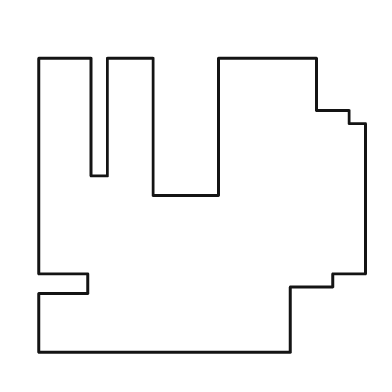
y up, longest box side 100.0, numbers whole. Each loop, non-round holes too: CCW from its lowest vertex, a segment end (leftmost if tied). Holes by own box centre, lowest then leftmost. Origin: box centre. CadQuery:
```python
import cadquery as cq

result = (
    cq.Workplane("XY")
    .moveTo(-50.0, -45.0)
    .lineTo(27.0, -45.0)
    .lineTo(27.0, -25.0)
    .lineTo(40.0, -25.0)
    .lineTo(40.0, -21.0)
    .lineTo(50.0, -21.0)
    .lineTo(50.0, 25.0)
    .lineTo(45.0, 25.0)
    .lineTo(45.0, 29.0)
    .lineTo(35.0, 29.0)
    .lineTo(35.0, 45.0)
    .lineTo(5.0, 45.0)
    .lineTo(5.0, 3.0)
    .lineTo(-15.0, 3.0)
    .lineTo(-15.0, 45.0)
    .lineTo(-29.0, 45.0)
    .lineTo(-29.0, 9.0)
    .lineTo(-34.0, 9.0)
    .lineTo(-34.0, 45.0)
    .lineTo(-50.0, 45.0)
    .lineTo(-50.0, -21.0)
    .lineTo(-35.0, -21.0)
    .lineTo(-35.0, -27.0)
    .lineTo(-50.0, -27.0)
    .close()
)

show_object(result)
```